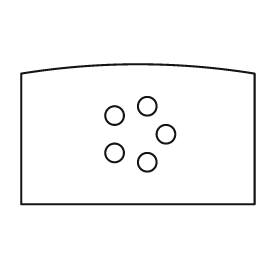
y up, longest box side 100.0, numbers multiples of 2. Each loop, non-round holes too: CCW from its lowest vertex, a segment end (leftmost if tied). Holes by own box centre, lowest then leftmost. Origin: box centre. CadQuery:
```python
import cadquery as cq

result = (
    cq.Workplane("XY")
    .moveTo(-50.0, -30.0)
    .lineTo(50.0, -30.0)
    .lineTo(50.0, 26.0)
    .threePointArc((0.0, 30.0), (-50.0, 26.0))
    .close()
    .moveTo(4.0, -12.0)
    .circle(4.0)
    .moveTo(-10.0, -8.0)
    .circle(4.0)
    .moveTo(12.0, 0.0)
    .circle(4.0)
    .moveTo(-10.0, 8.0)
    .circle(4.0)
    .moveTo(4.0, 12.0)
    .circle(4.0)
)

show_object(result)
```